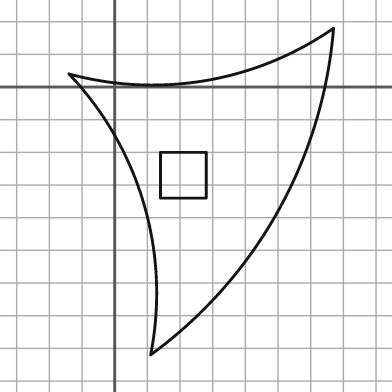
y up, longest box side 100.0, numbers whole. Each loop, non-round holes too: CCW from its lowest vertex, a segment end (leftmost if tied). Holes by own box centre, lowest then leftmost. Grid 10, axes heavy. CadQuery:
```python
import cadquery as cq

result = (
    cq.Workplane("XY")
    .moveTo(11.0, -82.0)
    .threePointArc((50.0, -38.0), (67.0, 18.0))
    .threePointArc((28.0, 2.0), (-14.0, 4.0))
    .threePointArc((9.0, -36.0), (11.0, -82.0))
    .close()
    .moveTo(14.0, -34.0)
    .lineTo(28.0, -34.0)
    .lineTo(28.0, -20.0)
    .lineTo(14.0, -20.0)
    .close()
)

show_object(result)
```